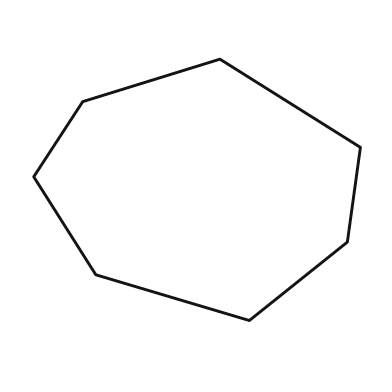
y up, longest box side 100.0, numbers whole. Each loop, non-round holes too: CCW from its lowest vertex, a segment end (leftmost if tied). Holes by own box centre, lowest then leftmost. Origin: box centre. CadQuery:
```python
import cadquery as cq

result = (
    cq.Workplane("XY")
    .moveTo(16.0, -40.0)
    .lineTo(46.0, -16.0)
    .lineTo(50.0, 13.0)
    .lineTo(7.0, 40.0)
    .lineTo(-35.0, 27.0)
    .lineTo(-50.0, 4.0)
    .lineTo(-31.0, -26.0)
    .close()
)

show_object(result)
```